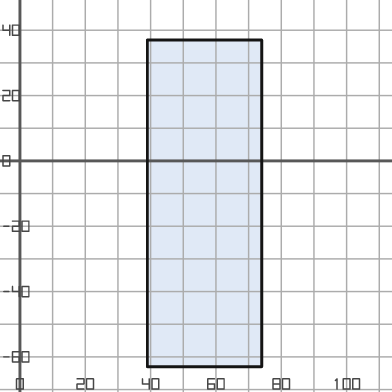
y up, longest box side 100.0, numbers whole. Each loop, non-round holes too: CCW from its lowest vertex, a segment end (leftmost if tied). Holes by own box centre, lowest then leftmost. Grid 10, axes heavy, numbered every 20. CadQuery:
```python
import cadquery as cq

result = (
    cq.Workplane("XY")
    .moveTo(39.0, -63.0)
    .lineTo(74.0, -63.0)
    .lineTo(74.0, 37.0)
    .lineTo(39.0, 37.0)
    .close()
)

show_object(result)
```